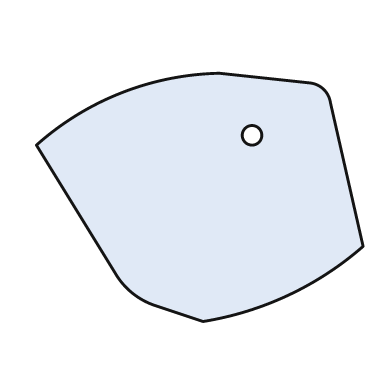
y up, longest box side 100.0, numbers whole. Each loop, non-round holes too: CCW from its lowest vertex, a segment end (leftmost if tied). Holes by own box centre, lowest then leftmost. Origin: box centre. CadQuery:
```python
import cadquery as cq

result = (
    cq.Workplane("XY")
    .moveTo(1.0, -38.0)
    .threePointArc((27.0, -30.0), (50.0, -15.0))
    .lineTo(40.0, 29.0)
    .threePointArc((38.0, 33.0), (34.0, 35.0))
    .lineTo(6.0, 38.0)
    .threePointArc((-24.0, 32.0), (-50.0, 16.0))
    .lineTo(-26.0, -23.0)
    .threePointArc((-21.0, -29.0), (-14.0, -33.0))
    .close()
    .moveTo(16.0, 19.0)
    .circle(3.0)
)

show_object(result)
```